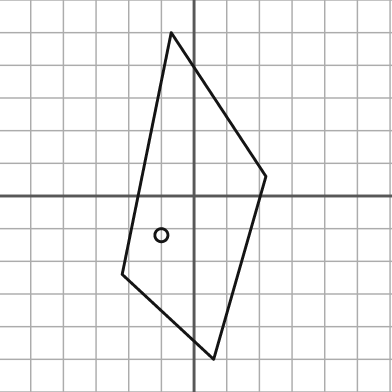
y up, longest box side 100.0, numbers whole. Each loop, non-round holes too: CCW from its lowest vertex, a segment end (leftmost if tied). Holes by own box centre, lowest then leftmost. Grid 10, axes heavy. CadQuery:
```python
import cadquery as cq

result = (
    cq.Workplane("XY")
    .moveTo(6.0, -50.0)
    .lineTo(22.0, 6.0)
    .lineTo(-7.0, 50.0)
    .lineTo(-22.0, -24.0)
    .close()
    .moveTo(-10.0, -12.0)
    .circle(2.0)
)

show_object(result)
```